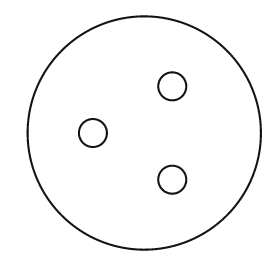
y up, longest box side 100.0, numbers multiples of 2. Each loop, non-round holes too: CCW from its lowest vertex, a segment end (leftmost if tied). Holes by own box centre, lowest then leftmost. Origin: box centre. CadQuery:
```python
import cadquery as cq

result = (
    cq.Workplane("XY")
    .moveTo(0.0, 0.0)
    .circle(50.0)
    .moveTo(12.0, -20.0)
    .circle(6.0)
    .moveTo(-22.0, 0.0)
    .circle(6.0)
    .moveTo(12.0, 20.0)
    .circle(6.0)
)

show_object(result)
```